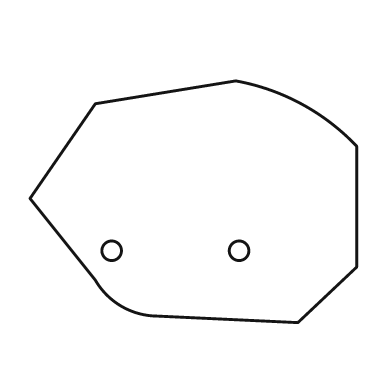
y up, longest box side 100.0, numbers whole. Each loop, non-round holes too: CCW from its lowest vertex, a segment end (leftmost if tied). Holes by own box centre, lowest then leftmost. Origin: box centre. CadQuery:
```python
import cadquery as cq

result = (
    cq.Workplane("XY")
    .moveTo(32.0, -37.0)
    .lineTo(50.0, -20.0)
    .lineTo(50.0, 17.0)
    .threePointArc((33.0, 30.0), (13.0, 37.0))
    .lineTo(-30.0, 30.0)
    .lineTo(-50.0, 1.0)
    .lineTo(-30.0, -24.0)
    .threePointArc((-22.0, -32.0), (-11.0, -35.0))
    .close()
    .moveTo(-25.0, -15.0)
    .circle(3.0)
    .moveTo(14.0, -15.0)
    .circle(3.0)
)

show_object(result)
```